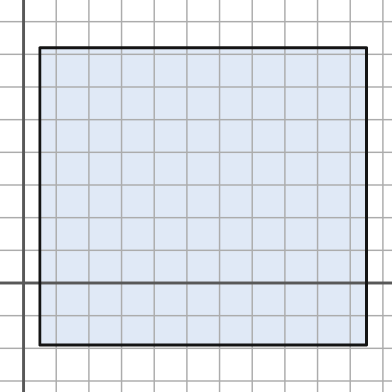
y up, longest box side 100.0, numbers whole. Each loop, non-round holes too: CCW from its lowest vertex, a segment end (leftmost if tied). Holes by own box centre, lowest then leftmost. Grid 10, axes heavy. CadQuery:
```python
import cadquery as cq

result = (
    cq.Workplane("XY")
    .moveTo(5.0, -19.0)
    .lineTo(105.0, -19.0)
    .lineTo(105.0, 72.0)
    .lineTo(5.0, 72.0)
    .close()
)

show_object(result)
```